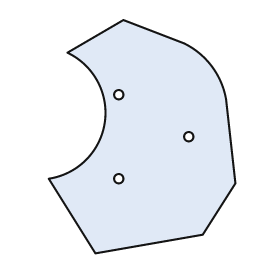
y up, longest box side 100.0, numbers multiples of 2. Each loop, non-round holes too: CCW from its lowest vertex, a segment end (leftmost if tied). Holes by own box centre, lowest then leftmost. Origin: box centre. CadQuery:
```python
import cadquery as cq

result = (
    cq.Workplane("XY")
    .moveTo(-20.0, -50.0)
    .lineTo(26.0, -42.0)
    .lineTo(40.0, -20.0)
    .lineTo(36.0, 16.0)
    .threePointArc((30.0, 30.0), (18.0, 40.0))
    .lineTo(-8.0, 50.0)
    .lineTo(-32.0, 36.0)
    .threePointArc((-16.0, 6.0), (-40.0, -18.0))
    .close()
    .moveTo(-10.0, -18.0)
    .circle(2.0)
    .moveTo(20.0, 0.0)
    .circle(2.0)
    .moveTo(-10.0, 18.0)
    .circle(2.0)
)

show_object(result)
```